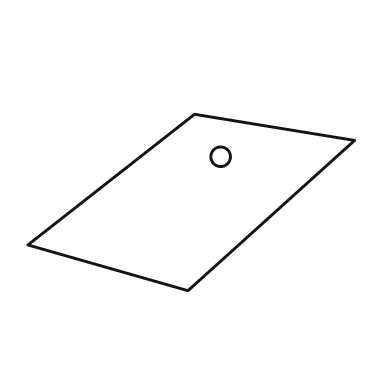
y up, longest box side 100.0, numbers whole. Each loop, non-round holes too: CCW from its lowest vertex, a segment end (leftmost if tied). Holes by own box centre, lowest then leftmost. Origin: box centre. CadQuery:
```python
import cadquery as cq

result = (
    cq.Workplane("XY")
    .moveTo(-1.0, -27.0)
    .lineTo(50.0, 19.0)
    .lineTo(1.0, 27.0)
    .lineTo(-50.0, -13.0)
    .close()
    .moveTo(9.0, 14.0)
    .circle(3.0)
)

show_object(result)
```